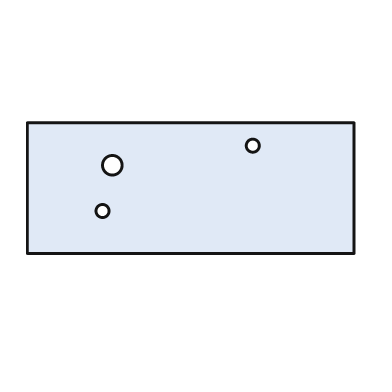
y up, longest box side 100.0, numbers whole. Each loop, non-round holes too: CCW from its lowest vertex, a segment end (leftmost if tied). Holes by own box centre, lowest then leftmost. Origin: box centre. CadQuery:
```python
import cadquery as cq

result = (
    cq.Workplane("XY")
    .moveTo(-50.0, -20.0)
    .lineTo(50.0, -20.0)
    .lineTo(50.0, 20.0)
    .lineTo(-50.0, 20.0)
    .close()
    .moveTo(-27.0, -7.0)
    .circle(2.0)
    .moveTo(-24.0, 7.0)
    .circle(3.0)
    .moveTo(19.0, 13.0)
    .circle(2.0)
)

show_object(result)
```